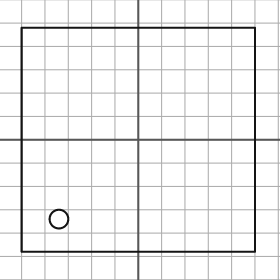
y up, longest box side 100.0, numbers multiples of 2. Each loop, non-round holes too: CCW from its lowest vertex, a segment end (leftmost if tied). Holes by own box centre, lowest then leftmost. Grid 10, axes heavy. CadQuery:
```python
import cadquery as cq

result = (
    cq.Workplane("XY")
    .moveTo(-50.0, -48.0)
    .lineTo(50.0, -48.0)
    .lineTo(50.0, 48.0)
    .lineTo(-50.0, 48.0)
    .close()
    .moveTo(-34.0, -34.0)
    .circle(4.0)
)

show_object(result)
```